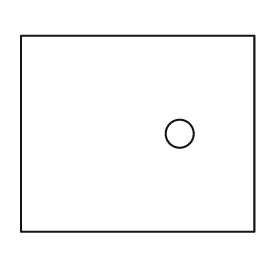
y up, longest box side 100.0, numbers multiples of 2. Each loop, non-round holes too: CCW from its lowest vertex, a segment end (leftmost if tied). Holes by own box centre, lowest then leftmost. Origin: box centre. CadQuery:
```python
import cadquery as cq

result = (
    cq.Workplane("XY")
    .moveTo(-50.0, -42.0)
    .lineTo(50.0, -42.0)
    .lineTo(50.0, 42.0)
    .lineTo(-50.0, 42.0)
    .close()
    .moveTo(18.0, 0.0)
    .circle(6.0)
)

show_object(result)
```